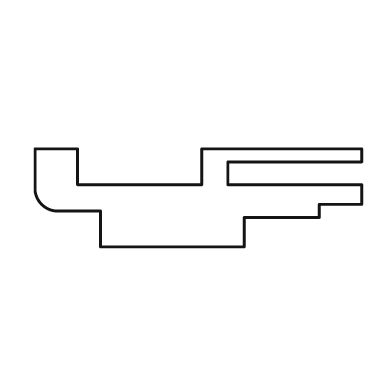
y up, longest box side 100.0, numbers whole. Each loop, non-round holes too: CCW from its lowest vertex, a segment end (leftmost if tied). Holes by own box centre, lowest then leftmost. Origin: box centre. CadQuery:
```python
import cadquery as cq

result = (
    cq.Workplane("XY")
    .moveTo(-30.0, -15.0)
    .lineTo(14.0, -15.0)
    .lineTo(14.0, -6.0)
    .lineTo(37.0, -6.0)
    .lineTo(37.0, -2.0)
    .lineTo(50.0, -2.0)
    .lineTo(50.0, 4.0)
    .lineTo(9.0, 4.0)
    .lineTo(9.0, 11.0)
    .lineTo(50.0, 11.0)
    .lineTo(50.0, 15.0)
    .lineTo(1.0, 15.0)
    .lineTo(1.0, 4.0)
    .lineTo(-37.0, 4.0)
    .lineTo(-37.0, 15.0)
    .lineTo(-50.0, 15.0)
    .lineTo(-50.0, 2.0)
    .threePointArc((-48.0, -2.0), (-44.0, -4.0))
    .lineTo(-30.0, -4.0)
    .close()
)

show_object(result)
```